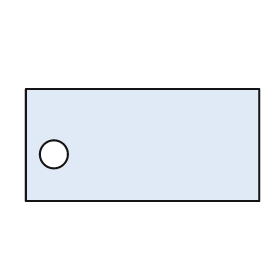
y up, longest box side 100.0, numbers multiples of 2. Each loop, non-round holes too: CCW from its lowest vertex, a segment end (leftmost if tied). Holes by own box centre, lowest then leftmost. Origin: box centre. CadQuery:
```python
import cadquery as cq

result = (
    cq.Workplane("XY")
    .moveTo(-50.0, -24.0)
    .lineTo(50.0, -24.0)
    .lineTo(50.0, 24.0)
    .lineTo(-50.0, 24.0)
    .close()
    .moveTo(-38.0, -4.0)
    .circle(6.0)
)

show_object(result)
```